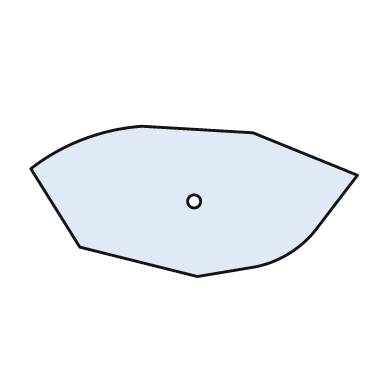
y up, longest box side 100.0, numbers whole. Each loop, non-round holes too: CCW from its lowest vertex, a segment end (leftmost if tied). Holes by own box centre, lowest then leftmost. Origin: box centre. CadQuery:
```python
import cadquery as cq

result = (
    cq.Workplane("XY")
    .moveTo(1.0, -23.0)
    .lineTo(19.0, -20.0)
    .threePointArc((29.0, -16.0), (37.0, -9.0))
    .lineTo(50.0, 8.0)
    .lineTo(18.0, 21.0)
    .lineTo(-16.0, 23.0)
    .threePointArc((-34.0, 19.0), (-50.0, 10.0))
    .lineTo(-35.0, -14.0)
    .close()
    .moveTo(0.0, 0.0)
    .circle(2.0)
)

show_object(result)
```